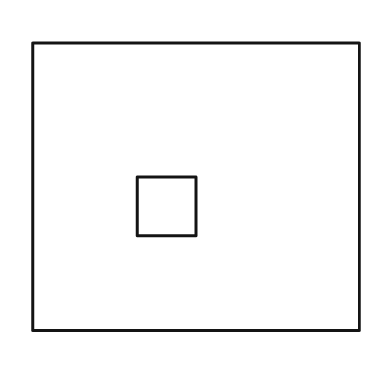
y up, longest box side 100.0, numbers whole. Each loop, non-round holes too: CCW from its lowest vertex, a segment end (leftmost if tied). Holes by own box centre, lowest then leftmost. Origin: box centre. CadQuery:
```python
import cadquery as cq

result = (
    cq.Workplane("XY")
    .moveTo(-50.0, -44.0)
    .lineTo(50.0, -44.0)
    .lineTo(50.0, 44.0)
    .lineTo(-50.0, 44.0)
    .close()
    .moveTo(-18.0, -15.0)
    .lineTo(0.0, -15.0)
    .lineTo(0.0, 3.0)
    .lineTo(-18.0, 3.0)
    .close()
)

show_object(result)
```